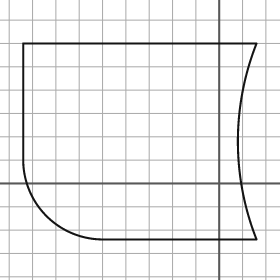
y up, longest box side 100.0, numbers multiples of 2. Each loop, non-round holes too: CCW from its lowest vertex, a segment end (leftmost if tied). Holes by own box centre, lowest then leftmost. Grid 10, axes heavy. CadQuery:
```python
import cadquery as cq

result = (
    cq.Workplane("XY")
    .moveTo(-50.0, -24.0)
    .lineTo(16.0, -24.0)
    .threePointArc((8.0, 18.0), (16.0, 60.0))
    .lineTo(-84.0, 60.0)
    .lineTo(-84.0, 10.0)
    .threePointArc((-74.0, -14.0), (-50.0, -24.0))
    .close()
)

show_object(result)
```